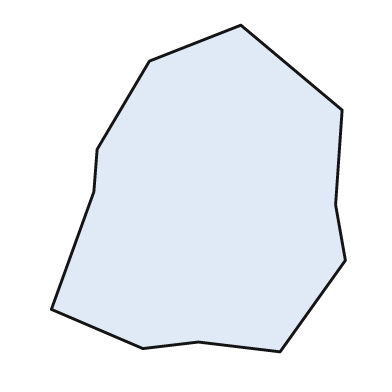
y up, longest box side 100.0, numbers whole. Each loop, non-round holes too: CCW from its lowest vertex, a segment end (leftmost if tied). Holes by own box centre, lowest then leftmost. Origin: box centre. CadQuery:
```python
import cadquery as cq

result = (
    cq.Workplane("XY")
    .moveTo(25.0, -50.0)
    .lineTo(45.0, -22.0)
    .lineTo(42.0, -5.0)
    .lineTo(44.0, 24.0)
    .lineTo(13.0, 50.0)
    .lineTo(-15.0, 39.0)
    .lineTo(-31.0, 12.0)
    .lineTo(-32.0, -1.0)
    .lineTo(-45.0, -37.0)
    .lineTo(-17.0, -49.0)
    .lineTo(0.0, -47.0)
    .close()
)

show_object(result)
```